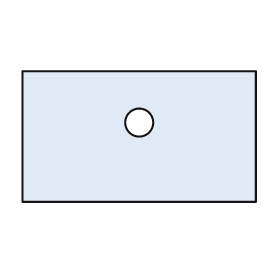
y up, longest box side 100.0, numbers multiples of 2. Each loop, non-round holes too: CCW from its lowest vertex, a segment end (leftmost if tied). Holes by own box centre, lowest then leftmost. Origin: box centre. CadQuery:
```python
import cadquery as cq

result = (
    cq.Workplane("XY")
    .moveTo(-50.0, -28.0)
    .lineTo(50.0, -28.0)
    .lineTo(50.0, 28.0)
    .lineTo(-50.0, 28.0)
    .close()
    .moveTo(0.0, 6.0)
    .circle(6.0)
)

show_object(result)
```